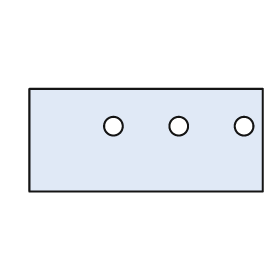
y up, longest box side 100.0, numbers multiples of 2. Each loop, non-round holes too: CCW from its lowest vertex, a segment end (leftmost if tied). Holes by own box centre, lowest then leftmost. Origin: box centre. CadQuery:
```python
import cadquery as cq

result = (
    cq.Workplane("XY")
    .moveTo(-50.0, -22.0)
    .lineTo(50.0, -22.0)
    .lineTo(50.0, 22.0)
    .lineTo(-50.0, 22.0)
    .close()
    .moveTo(-14.0, 6.0)
    .circle(4.0)
    .moveTo(14.0, 6.0)
    .circle(4.0)
    .moveTo(42.0, 6.0)
    .circle(4.0)
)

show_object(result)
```